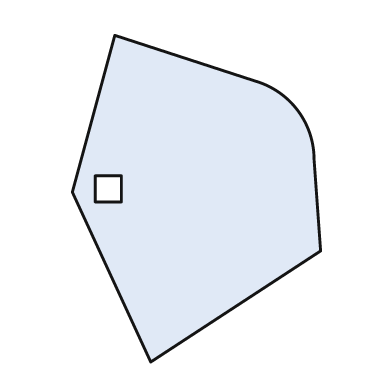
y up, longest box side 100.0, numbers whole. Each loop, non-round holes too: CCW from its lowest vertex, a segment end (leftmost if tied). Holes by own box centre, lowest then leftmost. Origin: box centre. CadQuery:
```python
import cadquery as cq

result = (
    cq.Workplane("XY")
    .moveTo(-14.0, -50.0)
    .lineTo(38.0, -16.0)
    .lineTo(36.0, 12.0)
    .threePointArc((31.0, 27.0), (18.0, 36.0))
    .lineTo(-25.0, 50.0)
    .lineTo(-38.0, 2.0)
    .close()
    .moveTo(-31.0, -1.0)
    .lineTo(-23.0, -1.0)
    .lineTo(-23.0, 7.0)
    .lineTo(-31.0, 7.0)
    .close()
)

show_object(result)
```